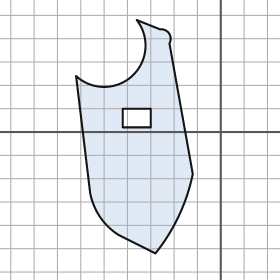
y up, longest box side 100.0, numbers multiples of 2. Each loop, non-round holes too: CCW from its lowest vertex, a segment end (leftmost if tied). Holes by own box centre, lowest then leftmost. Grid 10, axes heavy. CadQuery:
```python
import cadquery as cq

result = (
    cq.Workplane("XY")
    .moveTo(-28.0, -52.0)
    .threePointArc((-18.0, -36.0), (-12.0, -18.0))
    .lineTo(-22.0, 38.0)
    .threePointArc((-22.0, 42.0), (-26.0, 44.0))
    .lineTo(-36.0, 48.0)
    .threePointArc((-38.0, 24.0), (-62.0, 24.0))
    .lineTo(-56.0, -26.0)
    .threePointArc((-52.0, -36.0), (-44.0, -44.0))
    .close()
    .moveTo(-42.0, 2.0)
    .lineTo(-30.0, 2.0)
    .lineTo(-30.0, 10.0)
    .lineTo(-42.0, 10.0)
    .close()
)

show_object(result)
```